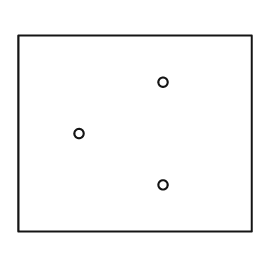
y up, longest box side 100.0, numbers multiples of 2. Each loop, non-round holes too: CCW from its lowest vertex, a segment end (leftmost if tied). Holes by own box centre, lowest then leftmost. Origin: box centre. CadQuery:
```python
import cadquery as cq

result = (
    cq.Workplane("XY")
    .moveTo(-50.0, -42.0)
    .lineTo(50.0, -42.0)
    .lineTo(50.0, 42.0)
    .lineTo(-50.0, 42.0)
    .close()
    .moveTo(12.0, -22.0)
    .circle(2.0)
    .moveTo(-24.0, 0.0)
    .circle(2.0)
    .moveTo(12.0, 22.0)
    .circle(2.0)
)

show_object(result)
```